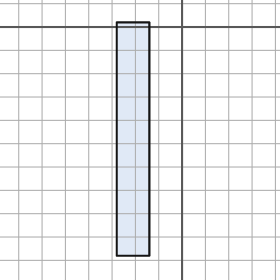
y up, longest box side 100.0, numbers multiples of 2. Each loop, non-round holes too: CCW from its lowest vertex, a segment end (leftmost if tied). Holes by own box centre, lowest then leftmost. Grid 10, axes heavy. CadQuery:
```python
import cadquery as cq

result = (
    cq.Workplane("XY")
    .moveTo(-28.0, -98.0)
    .lineTo(-14.0, -98.0)
    .lineTo(-14.0, 2.0)
    .lineTo(-28.0, 2.0)
    .close()
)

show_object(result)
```